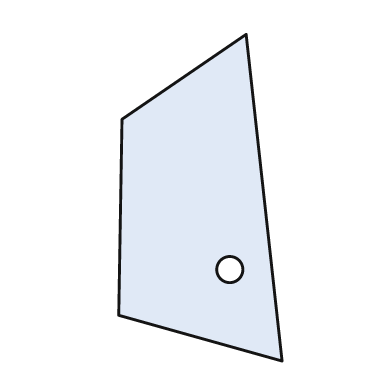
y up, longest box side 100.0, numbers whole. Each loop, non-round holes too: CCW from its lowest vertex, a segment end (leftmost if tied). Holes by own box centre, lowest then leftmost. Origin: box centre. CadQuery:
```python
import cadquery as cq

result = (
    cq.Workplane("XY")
    .moveTo(25.0, -50.0)
    .lineTo(14.0, 50.0)
    .lineTo(-24.0, 24.0)
    .lineTo(-25.0, -36.0)
    .close()
    .moveTo(9.0, -22.0)
    .circle(4.0)
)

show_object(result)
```